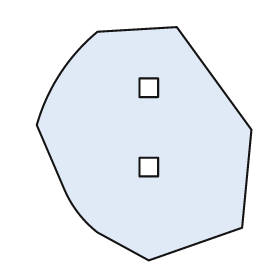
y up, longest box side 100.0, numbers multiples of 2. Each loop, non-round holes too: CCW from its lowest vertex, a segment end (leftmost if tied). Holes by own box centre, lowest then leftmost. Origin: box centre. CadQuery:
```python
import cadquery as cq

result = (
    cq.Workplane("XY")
    .moveTo(2.0, -50.0)
    .lineTo(42.0, -36.0)
    .lineTo(46.0, 6.0)
    .lineTo(14.0, 50.0)
    .lineTo(-20.0, 48.0)
    .threePointArc((-36.0, 30.0), (-46.0, 8.0))
    .lineTo(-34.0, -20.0)
    .threePointArc((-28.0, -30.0), (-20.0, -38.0))
    .close()
    .moveTo(-2.0, -14.0)
    .lineTo(6.0, -14.0)
    .lineTo(6.0, -6.0)
    .lineTo(-2.0, -6.0)
    .close()
    .moveTo(-2.0, 20.0)
    .lineTo(6.0, 20.0)
    .lineTo(6.0, 28.0)
    .lineTo(-2.0, 28.0)
    .close()
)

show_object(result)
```